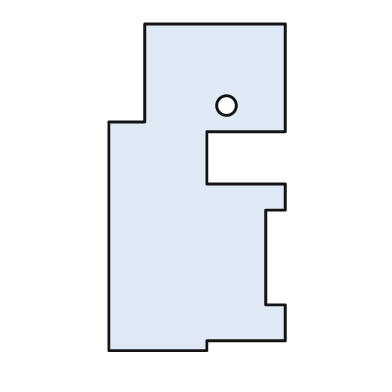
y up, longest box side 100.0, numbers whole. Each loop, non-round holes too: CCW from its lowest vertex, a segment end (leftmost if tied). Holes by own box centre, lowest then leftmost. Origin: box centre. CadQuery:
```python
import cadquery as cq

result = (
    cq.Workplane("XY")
    .moveTo(-27.0, -50.0)
    .lineTo(3.0, -50.0)
    .lineTo(3.0, -47.0)
    .lineTo(27.0, -47.0)
    .lineTo(27.0, -36.0)
    .lineTo(21.0, -36.0)
    .lineTo(21.0, -7.0)
    .lineTo(27.0, -7.0)
    .lineTo(27.0, 1.0)
    .lineTo(3.0, 1.0)
    .lineTo(3.0, 17.0)
    .lineTo(27.0, 17.0)
    .lineTo(27.0, 50.0)
    .lineTo(-16.0, 50.0)
    .lineTo(-16.0, 20.0)
    .lineTo(-27.0, 20.0)
    .close()
    .moveTo(9.0, 25.0)
    .circle(3.0)
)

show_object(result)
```